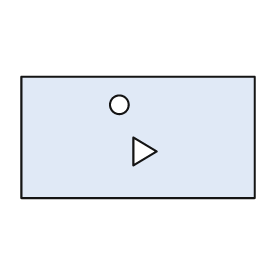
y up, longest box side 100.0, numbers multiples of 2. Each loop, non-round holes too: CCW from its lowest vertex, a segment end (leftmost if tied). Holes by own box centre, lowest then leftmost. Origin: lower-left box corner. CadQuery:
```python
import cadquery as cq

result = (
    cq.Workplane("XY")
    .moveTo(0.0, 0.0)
    .lineTo(100.0, 0.0)
    .lineTo(100.0, 52.0)
    .lineTo(0.0, 52.0)
    .close()
    .moveTo(48.0, 14.0)
    .lineTo(58.0, 20.0)
    .lineTo(48.0, 26.0)
    .close()
    .moveTo(42.0, 40.0)
    .circle(4.0)
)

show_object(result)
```